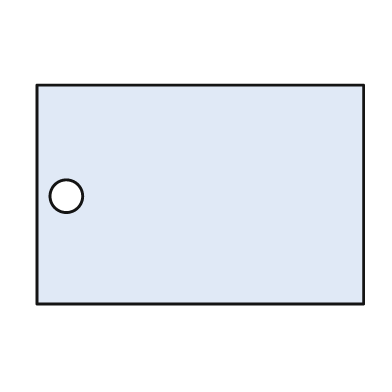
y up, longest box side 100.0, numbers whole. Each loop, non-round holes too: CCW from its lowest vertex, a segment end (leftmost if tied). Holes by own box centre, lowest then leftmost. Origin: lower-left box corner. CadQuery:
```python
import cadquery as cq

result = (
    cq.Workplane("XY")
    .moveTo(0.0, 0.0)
    .lineTo(100.0, 0.0)
    .lineTo(100.0, 67.0)
    .lineTo(0.0, 67.0)
    .close()
    .moveTo(9.0, 33.0)
    .circle(5.0)
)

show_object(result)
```